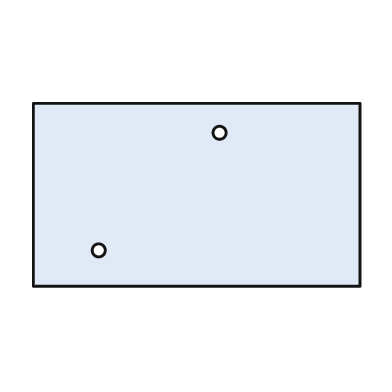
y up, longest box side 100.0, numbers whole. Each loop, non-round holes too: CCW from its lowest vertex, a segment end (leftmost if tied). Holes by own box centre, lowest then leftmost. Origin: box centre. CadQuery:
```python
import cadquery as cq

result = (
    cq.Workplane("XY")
    .moveTo(-50.0, -28.0)
    .lineTo(50.0, -28.0)
    .lineTo(50.0, 28.0)
    .lineTo(-50.0, 28.0)
    .close()
    .moveTo(-30.0, -17.0)
    .circle(2.0)
    .moveTo(7.0, 19.0)
    .circle(2.0)
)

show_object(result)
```